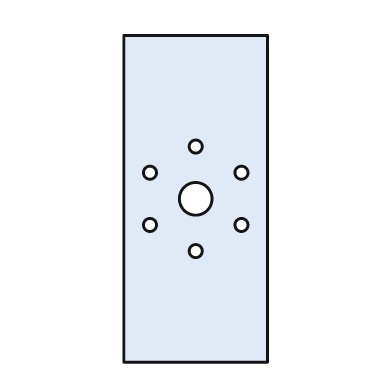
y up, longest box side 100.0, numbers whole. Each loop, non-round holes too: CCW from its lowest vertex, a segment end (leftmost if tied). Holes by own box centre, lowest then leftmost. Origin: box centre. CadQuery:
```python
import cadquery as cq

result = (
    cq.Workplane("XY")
    .moveTo(-22.0, -50.0)
    .lineTo(22.0, -50.0)
    .lineTo(22.0, 50.0)
    .lineTo(-22.0, 50.0)
    .close()
    .moveTo(0.0, -16.0)
    .circle(2.0)
    .moveTo(-14.0, -8.0)
    .circle(2.0)
    .moveTo(14.0, -8.0)
    .circle(2.0)
    .moveTo(0.0, 0.0)
    .circle(5.0)
    .moveTo(-14.0, 8.0)
    .circle(2.0)
    .moveTo(14.0, 8.0)
    .circle(2.0)
    .moveTo(0.0, 16.0)
    .circle(2.0)
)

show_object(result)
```